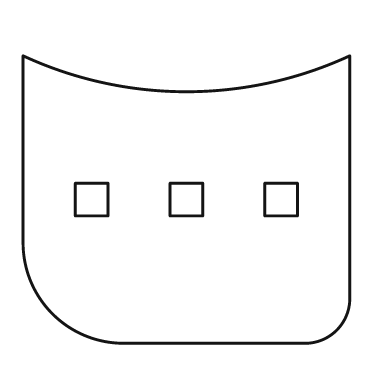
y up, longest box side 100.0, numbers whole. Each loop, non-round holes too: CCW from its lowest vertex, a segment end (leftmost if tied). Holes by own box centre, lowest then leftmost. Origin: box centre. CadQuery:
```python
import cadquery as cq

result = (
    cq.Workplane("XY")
    .moveTo(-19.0, -44.0)
    .lineTo(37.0, -44.0)
    .threePointArc((46.0, -40.0), (50.0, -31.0))
    .lineTo(50.0, 44.0)
    .threePointArc((0.0, 33.0), (-50.0, 44.0))
    .lineTo(-50.0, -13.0)
    .threePointArc((-41.0, -35.0), (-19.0, -44.0))
    .close()
    .moveTo(-34.0, -5.0)
    .lineTo(-24.0, -5.0)
    .lineTo(-24.0, 5.0)
    .lineTo(-34.0, 5.0)
    .close()
    .moveTo(-5.0, -5.0)
    .lineTo(5.0, -5.0)
    .lineTo(5.0, 5.0)
    .lineTo(-5.0, 5.0)
    .close()
    .moveTo(24.0, -5.0)
    .lineTo(34.0, -5.0)
    .lineTo(34.0, 5.0)
    .lineTo(24.0, 5.0)
    .close()
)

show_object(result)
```